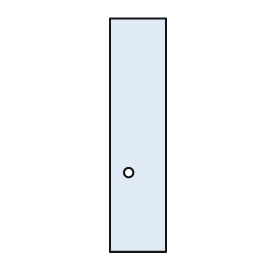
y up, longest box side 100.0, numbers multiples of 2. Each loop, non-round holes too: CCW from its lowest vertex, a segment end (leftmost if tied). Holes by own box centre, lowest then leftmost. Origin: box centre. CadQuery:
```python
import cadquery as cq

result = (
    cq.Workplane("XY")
    .moveTo(-12.0, -50.0)
    .lineTo(12.0, -50.0)
    .lineTo(12.0, 50.0)
    .lineTo(-12.0, 50.0)
    .close()
    .moveTo(-4.0, -16.0)
    .circle(2.0)
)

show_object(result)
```